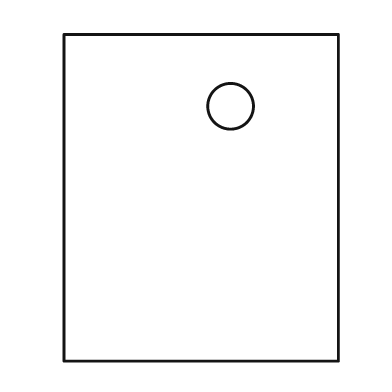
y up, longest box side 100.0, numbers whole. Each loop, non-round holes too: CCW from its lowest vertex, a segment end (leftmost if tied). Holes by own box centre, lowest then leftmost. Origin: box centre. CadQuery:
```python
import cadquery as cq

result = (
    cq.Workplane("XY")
    .moveTo(-42.0, -50.0)
    .lineTo(42.0, -50.0)
    .lineTo(42.0, 50.0)
    .lineTo(-42.0, 50.0)
    .close()
    .moveTo(9.0, 28.0)
    .circle(7.0)
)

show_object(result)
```